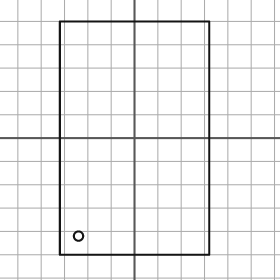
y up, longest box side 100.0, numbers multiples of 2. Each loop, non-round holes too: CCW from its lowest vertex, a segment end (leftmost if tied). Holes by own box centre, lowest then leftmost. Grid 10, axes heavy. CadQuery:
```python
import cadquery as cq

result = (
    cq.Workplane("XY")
    .moveTo(-32.0, -50.0)
    .lineTo(32.0, -50.0)
    .lineTo(32.0, 50.0)
    .lineTo(-32.0, 50.0)
    .close()
    .moveTo(-24.0, -42.0)
    .circle(2.0)
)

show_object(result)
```